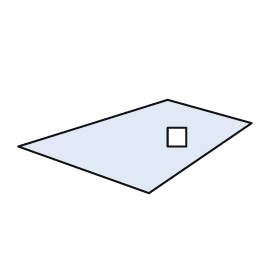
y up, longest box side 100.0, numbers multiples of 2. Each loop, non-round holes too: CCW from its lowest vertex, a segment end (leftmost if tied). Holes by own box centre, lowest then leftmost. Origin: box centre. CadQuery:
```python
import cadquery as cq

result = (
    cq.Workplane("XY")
    .moveTo(6.0, -20.0)
    .lineTo(50.0, 10.0)
    .lineTo(14.0, 20.0)
    .lineTo(-50.0, 0.0)
    .close()
    .moveTo(14.0, 0.0)
    .lineTo(22.0, 0.0)
    .lineTo(22.0, 8.0)
    .lineTo(14.0, 8.0)
    .close()
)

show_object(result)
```